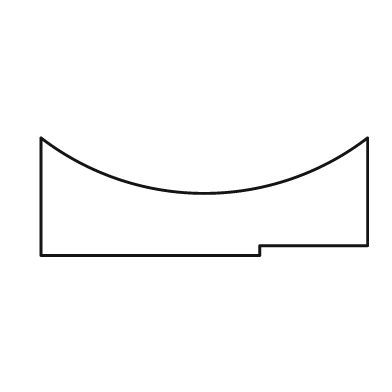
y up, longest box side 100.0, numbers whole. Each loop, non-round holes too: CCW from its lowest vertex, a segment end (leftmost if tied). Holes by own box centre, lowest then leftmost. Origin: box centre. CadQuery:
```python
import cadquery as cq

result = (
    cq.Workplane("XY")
    .moveTo(-50.0, -18.0)
    .lineTo(17.0, -18.0)
    .lineTo(17.0, -15.0)
    .lineTo(50.0, -15.0)
    .lineTo(50.0, 18.0)
    .threePointArc((0.0, 1.0), (-50.0, 18.0))
    .close()
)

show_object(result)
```